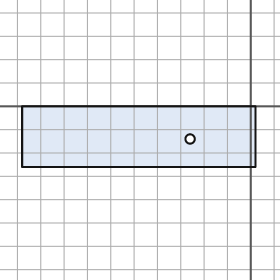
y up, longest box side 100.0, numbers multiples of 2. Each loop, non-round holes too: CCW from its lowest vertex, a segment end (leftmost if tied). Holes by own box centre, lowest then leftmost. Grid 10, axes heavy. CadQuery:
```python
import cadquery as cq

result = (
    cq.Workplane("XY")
    .moveTo(-98.0, -26.0)
    .lineTo(2.0, -26.0)
    .lineTo(2.0, 0.0)
    .lineTo(-98.0, 0.0)
    .close()
    .moveTo(-26.0, -14.0)
    .circle(2.0)
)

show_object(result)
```